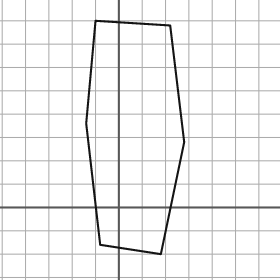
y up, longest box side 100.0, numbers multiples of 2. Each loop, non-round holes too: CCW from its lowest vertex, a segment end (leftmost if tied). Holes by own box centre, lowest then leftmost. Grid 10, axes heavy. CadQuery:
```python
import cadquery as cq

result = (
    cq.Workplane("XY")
    .moveTo(18.0, -20.0)
    .lineTo(28.0, 28.0)
    .lineTo(22.0, 78.0)
    .lineTo(-10.0, 80.0)
    .lineTo(-14.0, 36.0)
    .lineTo(-8.0, -16.0)
    .close()
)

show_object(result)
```